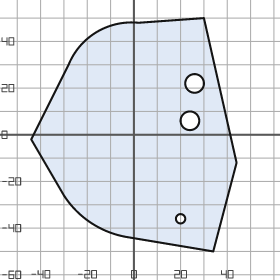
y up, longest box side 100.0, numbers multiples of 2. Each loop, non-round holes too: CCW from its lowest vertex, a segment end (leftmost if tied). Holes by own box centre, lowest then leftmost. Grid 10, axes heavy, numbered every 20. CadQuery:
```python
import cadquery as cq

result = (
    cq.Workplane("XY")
    .moveTo(34.0, -50.0)
    .lineTo(44.0, -12.0)
    .lineTo(30.0, 50.0)
    .lineTo(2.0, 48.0)
    .threePointArc((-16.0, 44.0), (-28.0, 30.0))
    .lineTo(-44.0, -2.0)
    .lineTo(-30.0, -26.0)
    .threePointArc((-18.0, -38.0), (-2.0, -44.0))
    .close()
    .moveTo(20.0, -36.0)
    .circle(2.0)
    .moveTo(24.0, 6.0)
    .circle(4.0)
    .moveTo(26.0, 22.0)
    .circle(4.0)
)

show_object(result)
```